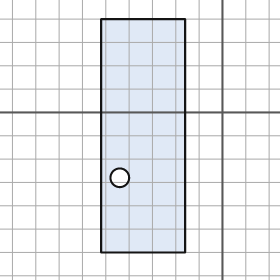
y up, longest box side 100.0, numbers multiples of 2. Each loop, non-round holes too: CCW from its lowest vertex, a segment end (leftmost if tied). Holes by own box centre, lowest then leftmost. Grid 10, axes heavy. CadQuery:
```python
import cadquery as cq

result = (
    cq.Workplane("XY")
    .moveTo(-52.0, -60.0)
    .lineTo(-16.0, -60.0)
    .lineTo(-16.0, 40.0)
    .lineTo(-52.0, 40.0)
    .close()
    .moveTo(-44.0, -28.0)
    .circle(4.0)
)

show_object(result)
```